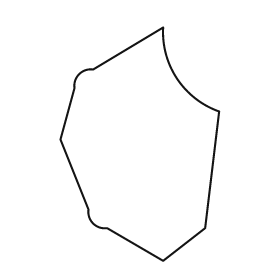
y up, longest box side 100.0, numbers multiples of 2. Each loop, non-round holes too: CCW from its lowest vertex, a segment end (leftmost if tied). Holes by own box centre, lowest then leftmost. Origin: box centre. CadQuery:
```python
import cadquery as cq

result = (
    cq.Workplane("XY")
    .moveTo(10.0, -50.0)
    .lineTo(28.0, -36.0)
    .lineTo(34.0, 14.0)
    .threePointArc((16.0, 28.0), (10.0, 50.0))
    .lineTo(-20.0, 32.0)
    .threePointArc((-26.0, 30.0), (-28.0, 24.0))
    .lineTo(-34.0, 2.0)
    .lineTo(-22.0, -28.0)
    .threePointArc((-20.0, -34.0), (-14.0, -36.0))
    .close()
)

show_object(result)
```